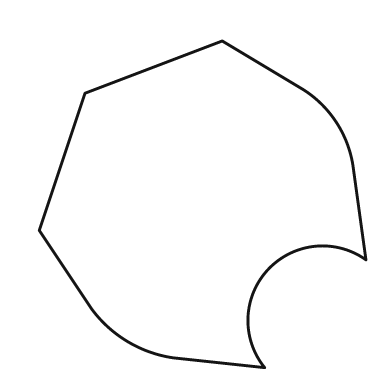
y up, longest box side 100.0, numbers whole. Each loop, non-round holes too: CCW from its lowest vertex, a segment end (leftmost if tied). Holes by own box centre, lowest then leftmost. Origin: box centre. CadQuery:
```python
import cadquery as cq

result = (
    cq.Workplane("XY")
    .moveTo(19.0, -50.0)
    .threePointArc((20.0, -20.0), (50.0, -17.0))
    .lineTo(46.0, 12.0)
    .threePointArc((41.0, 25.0), (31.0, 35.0))
    .lineTo(6.0, 50.0)
    .lineTo(-36.0, 34.0)
    .lineTo(-50.0, -8.0)
    .lineTo(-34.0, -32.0)
    .threePointArc((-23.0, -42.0), (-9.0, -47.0))
    .close()
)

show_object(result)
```